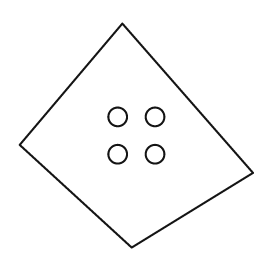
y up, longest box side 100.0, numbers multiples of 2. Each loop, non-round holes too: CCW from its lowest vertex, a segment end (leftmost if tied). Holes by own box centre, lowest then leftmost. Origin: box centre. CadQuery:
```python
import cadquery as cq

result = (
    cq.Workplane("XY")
    .moveTo(-2.0, -48.0)
    .lineTo(50.0, -16.0)
    .lineTo(-6.0, 48.0)
    .lineTo(-50.0, -4.0)
    .close()
    .moveTo(-8.0, -8.0)
    .circle(4.0)
    .moveTo(8.0, -8.0)
    .circle(4.0)
    .moveTo(-8.0, 8.0)
    .circle(4.0)
    .moveTo(8.0, 8.0)
    .circle(4.0)
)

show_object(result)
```